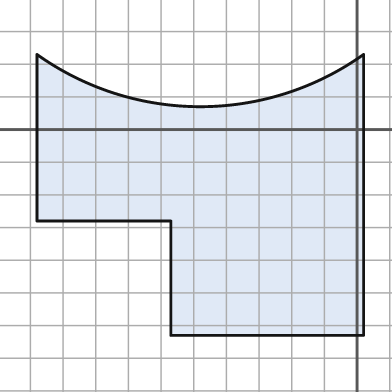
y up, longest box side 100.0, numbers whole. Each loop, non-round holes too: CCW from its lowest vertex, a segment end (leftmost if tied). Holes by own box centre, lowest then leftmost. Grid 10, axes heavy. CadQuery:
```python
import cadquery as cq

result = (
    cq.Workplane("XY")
    .moveTo(-57.0, -63.0)
    .lineTo(2.0, -63.0)
    .lineTo(2.0, 23.0)
    .threePointArc((-48.0, 7.0), (-98.0, 23.0))
    .lineTo(-98.0, -28.0)
    .lineTo(-57.0, -28.0)
    .close()
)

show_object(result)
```